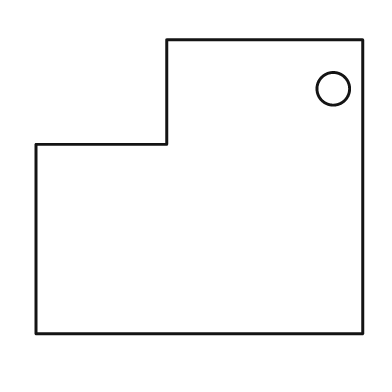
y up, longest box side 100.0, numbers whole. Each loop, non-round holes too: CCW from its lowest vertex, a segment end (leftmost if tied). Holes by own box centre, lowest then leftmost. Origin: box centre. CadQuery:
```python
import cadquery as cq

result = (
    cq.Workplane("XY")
    .moveTo(-50.0, -45.0)
    .lineTo(50.0, -45.0)
    .lineTo(50.0, 45.0)
    .lineTo(-10.0, 45.0)
    .lineTo(-10.0, 13.0)
    .lineTo(-50.0, 13.0)
    .close()
    .moveTo(41.0, 30.0)
    .circle(5.0)
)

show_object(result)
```